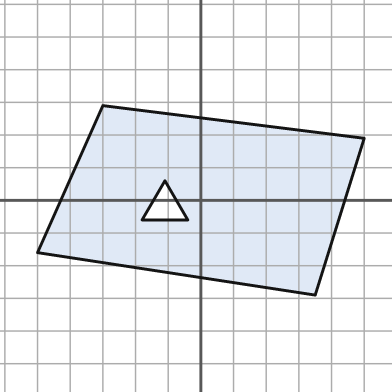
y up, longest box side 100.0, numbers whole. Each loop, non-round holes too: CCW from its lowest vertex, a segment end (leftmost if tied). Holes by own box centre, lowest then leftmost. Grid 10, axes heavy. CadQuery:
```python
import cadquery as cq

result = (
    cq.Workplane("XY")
    .moveTo(35.0, -29.0)
    .lineTo(50.0, 19.0)
    .lineTo(-30.0, 29.0)
    .lineTo(-50.0, -16.0)
    .close()
    .moveTo(-18.0, -6.0)
    .lineTo(-4.0, -6.0)
    .lineTo(-11.0, 6.0)
    .close()
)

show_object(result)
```